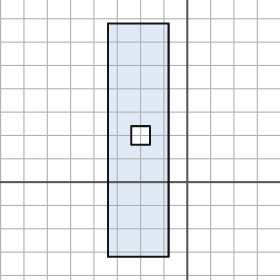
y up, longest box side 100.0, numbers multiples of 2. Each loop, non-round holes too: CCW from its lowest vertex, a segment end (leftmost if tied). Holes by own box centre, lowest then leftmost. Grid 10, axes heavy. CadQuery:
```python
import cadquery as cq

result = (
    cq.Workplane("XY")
    .moveTo(-34.0, -32.0)
    .lineTo(-8.0, -32.0)
    .lineTo(-8.0, 68.0)
    .lineTo(-34.0, 68.0)
    .close()
    .moveTo(-24.0, 16.0)
    .lineTo(-16.0, 16.0)
    .lineTo(-16.0, 24.0)
    .lineTo(-24.0, 24.0)
    .close()
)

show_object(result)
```